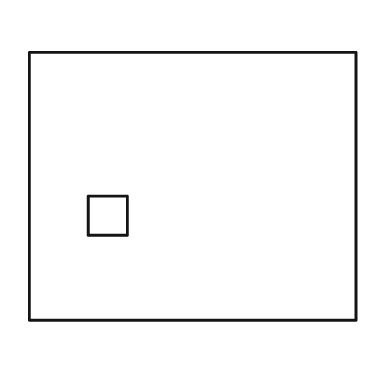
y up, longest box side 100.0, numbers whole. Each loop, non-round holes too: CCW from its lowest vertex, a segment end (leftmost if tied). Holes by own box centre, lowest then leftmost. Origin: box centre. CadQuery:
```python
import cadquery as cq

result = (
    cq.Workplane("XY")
    .moveTo(-50.0, -41.0)
    .lineTo(50.0, -41.0)
    .lineTo(50.0, 41.0)
    .lineTo(-50.0, 41.0)
    .close()
    .moveTo(-32.0, -15.0)
    .lineTo(-20.0, -15.0)
    .lineTo(-20.0, -3.0)
    .lineTo(-32.0, -3.0)
    .close()
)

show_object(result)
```